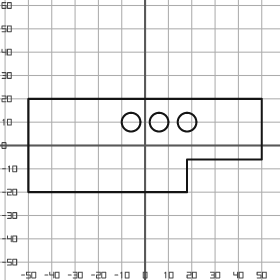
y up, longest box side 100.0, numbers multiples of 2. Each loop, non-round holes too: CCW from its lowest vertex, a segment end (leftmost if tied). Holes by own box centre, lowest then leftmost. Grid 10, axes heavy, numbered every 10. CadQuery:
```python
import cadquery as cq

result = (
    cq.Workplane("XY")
    .moveTo(-50.0, -20.0)
    .lineTo(18.0, -20.0)
    .lineTo(18.0, -6.0)
    .lineTo(50.0, -6.0)
    .lineTo(50.0, 20.0)
    .lineTo(-50.0, 20.0)
    .close()
    .moveTo(-6.0, 10.0)
    .circle(4.0)
    .moveTo(6.0, 10.0)
    .circle(4.0)
    .moveTo(18.0, 10.0)
    .circle(4.0)
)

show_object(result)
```